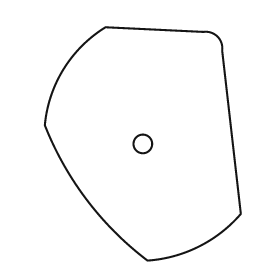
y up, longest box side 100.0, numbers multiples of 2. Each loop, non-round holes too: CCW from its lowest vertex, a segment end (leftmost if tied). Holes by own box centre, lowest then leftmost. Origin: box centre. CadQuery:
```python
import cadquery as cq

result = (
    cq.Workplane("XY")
    .moveTo(2.0, -50.0)
    .threePointArc((24.0, -44.0), (42.0, -30.0))
    .lineTo(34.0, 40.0)
    .threePointArc((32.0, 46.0), (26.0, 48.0))
    .lineTo(-16.0, 50.0)
    .threePointArc((-34.0, 32.0), (-42.0, 8.0))
    .threePointArc((-24.0, -24.0), (2.0, -50.0))
    .close()
    .moveTo(0.0, 0.0)
    .circle(4.0)
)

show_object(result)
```